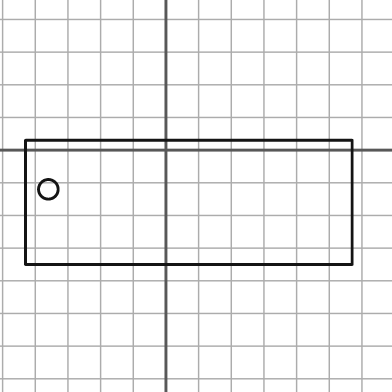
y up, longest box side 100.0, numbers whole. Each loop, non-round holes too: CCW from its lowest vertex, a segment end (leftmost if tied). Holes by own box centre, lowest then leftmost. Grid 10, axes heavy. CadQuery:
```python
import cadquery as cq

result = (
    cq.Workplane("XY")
    .moveTo(-43.0, -35.0)
    .lineTo(57.0, -35.0)
    .lineTo(57.0, 3.0)
    .lineTo(-43.0, 3.0)
    .close()
    .moveTo(-36.0, -12.0)
    .circle(3.0)
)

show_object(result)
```